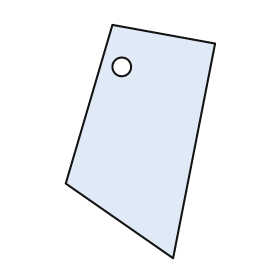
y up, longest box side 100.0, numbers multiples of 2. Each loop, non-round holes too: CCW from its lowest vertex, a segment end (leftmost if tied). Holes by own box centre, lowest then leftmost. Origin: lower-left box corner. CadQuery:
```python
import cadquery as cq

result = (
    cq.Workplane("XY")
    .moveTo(46.0, 0.0)
    .lineTo(64.0, 92.0)
    .lineTo(20.0, 100.0)
    .lineTo(0.0, 32.0)
    .close()
    .moveTo(24.0, 82.0)
    .circle(4.0)
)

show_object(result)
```